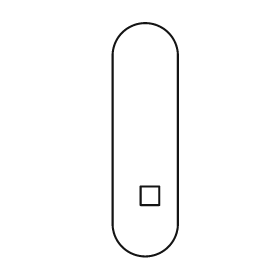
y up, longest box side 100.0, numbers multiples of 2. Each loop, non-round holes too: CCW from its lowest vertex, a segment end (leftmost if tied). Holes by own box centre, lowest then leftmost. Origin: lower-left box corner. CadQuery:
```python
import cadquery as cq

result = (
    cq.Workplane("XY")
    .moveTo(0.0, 14.0)
    .threePointArc((14.0, 0.0), (28.0, 14.0))
    .lineTo(28.0, 86.0)
    .threePointArc((14.0, 100.0), (0.0, 86.0))
    .close()
    .moveTo(12.0, 22.0)
    .lineTo(20.0, 22.0)
    .lineTo(20.0, 30.0)
    .lineTo(12.0, 30.0)
    .close()
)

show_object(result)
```